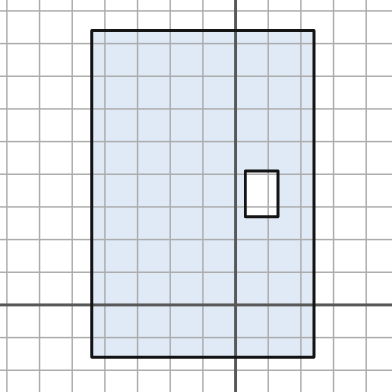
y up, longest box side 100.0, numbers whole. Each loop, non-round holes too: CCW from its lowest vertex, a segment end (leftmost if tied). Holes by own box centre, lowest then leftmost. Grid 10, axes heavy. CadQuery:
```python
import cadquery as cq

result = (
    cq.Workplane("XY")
    .moveTo(-44.0, -16.0)
    .lineTo(24.0, -16.0)
    .lineTo(24.0, 84.0)
    .lineTo(-44.0, 84.0)
    .close()
    .moveTo(3.0, 27.0)
    .lineTo(13.0, 27.0)
    .lineTo(13.0, 41.0)
    .lineTo(3.0, 41.0)
    .close()
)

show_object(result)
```